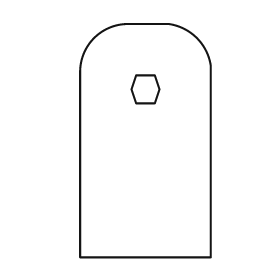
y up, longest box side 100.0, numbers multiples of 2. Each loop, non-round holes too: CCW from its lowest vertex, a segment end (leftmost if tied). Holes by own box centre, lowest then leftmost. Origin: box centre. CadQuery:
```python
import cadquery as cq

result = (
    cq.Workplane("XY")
    .moveTo(-28.0, -50.0)
    .lineTo(28.0, -50.0)
    .lineTo(28.0, 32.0)
    .threePointArc((22.0, 44.0), (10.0, 50.0))
    .lineTo(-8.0, 50.0)
    .threePointArc((-22.0, 44.0), (-28.0, 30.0))
    .close()
    .moveTo(-4.0, 16.0)
    .lineTo(4.0, 16.0)
    .lineTo(6.0, 22.0)
    .lineTo(4.0, 28.0)
    .lineTo(-4.0, 28.0)
    .lineTo(-6.0, 22.0)
    .close()
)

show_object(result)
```